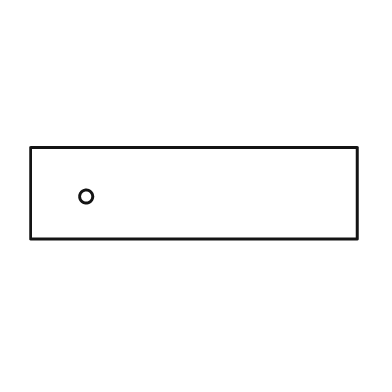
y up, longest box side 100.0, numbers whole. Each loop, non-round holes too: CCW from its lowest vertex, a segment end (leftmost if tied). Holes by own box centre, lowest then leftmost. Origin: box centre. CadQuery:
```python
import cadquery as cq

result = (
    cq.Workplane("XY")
    .moveTo(-50.0, -14.0)
    .lineTo(50.0, -14.0)
    .lineTo(50.0, 14.0)
    .lineTo(-50.0, 14.0)
    .close()
    .moveTo(-33.0, -1.0)
    .circle(2.0)
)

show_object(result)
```